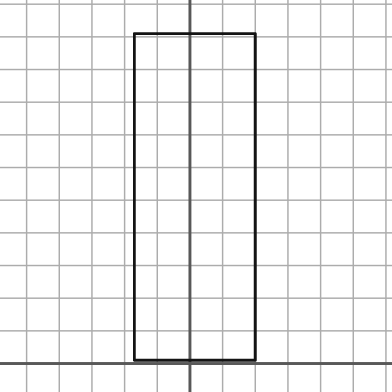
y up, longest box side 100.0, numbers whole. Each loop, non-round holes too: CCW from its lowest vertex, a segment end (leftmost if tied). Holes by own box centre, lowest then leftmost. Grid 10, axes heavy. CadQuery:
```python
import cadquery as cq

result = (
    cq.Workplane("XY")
    .moveTo(-17.0, 1.0)
    .lineTo(20.0, 1.0)
    .lineTo(20.0, 101.0)
    .lineTo(-17.0, 101.0)
    .close()
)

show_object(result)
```